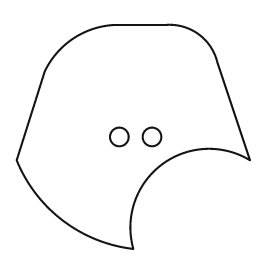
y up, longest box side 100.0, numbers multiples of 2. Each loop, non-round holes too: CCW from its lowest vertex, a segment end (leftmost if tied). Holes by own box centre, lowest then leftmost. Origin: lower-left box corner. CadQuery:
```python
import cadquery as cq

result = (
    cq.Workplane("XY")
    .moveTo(50.0, 0.0)
    .threePointArc((62.0, 36.0), (100.0, 38.0))
    .lineTo(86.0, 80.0)
    .threePointArc((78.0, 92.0), (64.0, 96.0))
    .lineTo(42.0, 96.0)
    .threePointArc((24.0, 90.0), (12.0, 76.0))
    .lineTo(0.0, 38.0)
    .threePointArc((20.0, 12.0), (50.0, 0.0))
    .close()
    .moveTo(44.0, 48.0)
    .circle(4.0)
    .moveTo(58.0, 48.0)
    .circle(4.0)
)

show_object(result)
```